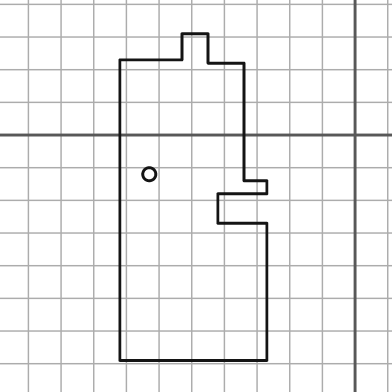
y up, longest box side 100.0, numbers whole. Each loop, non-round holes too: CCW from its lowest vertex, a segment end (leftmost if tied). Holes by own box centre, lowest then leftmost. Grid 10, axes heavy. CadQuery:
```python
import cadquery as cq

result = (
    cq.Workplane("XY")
    .moveTo(-72.0, -69.0)
    .lineTo(-27.0, -69.0)
    .lineTo(-27.0, -27.0)
    .lineTo(-42.0, -27.0)
    .lineTo(-42.0, -18.0)
    .lineTo(-27.0, -18.0)
    .lineTo(-27.0, -14.0)
    .lineTo(-34.0, -14.0)
    .lineTo(-34.0, 22.0)
    .lineTo(-45.0, 22.0)
    .lineTo(-45.0, 31.0)
    .lineTo(-53.0, 31.0)
    .lineTo(-53.0, 23.0)
    .lineTo(-72.0, 23.0)
    .close()
    .moveTo(-63.0, -12.0)
    .circle(2.0)
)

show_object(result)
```